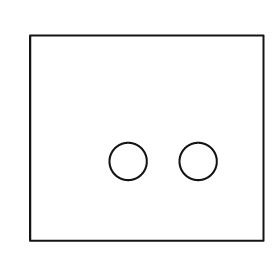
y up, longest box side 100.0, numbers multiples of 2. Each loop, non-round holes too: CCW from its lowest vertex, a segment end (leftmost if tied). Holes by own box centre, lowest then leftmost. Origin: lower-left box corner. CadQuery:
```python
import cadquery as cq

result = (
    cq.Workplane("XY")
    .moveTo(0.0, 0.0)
    .lineTo(100.0, 0.0)
    .lineTo(100.0, 88.0)
    .lineTo(0.0, 88.0)
    .close()
    .moveTo(42.0, 34.0)
    .circle(8.0)
    .moveTo(72.0, 34.0)
    .circle(8.0)
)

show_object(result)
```